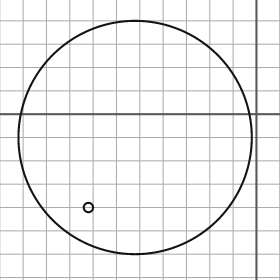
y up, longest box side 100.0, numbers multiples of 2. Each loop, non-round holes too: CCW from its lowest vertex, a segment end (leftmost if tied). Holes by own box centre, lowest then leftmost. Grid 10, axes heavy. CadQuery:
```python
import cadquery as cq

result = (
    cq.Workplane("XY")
    .moveTo(-52.0, -10.0)
    .circle(50.0)
    .moveTo(-72.0, -40.0)
    .circle(2.0)
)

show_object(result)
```